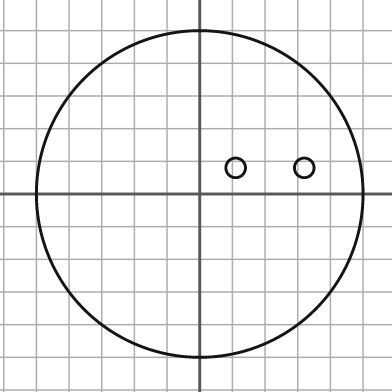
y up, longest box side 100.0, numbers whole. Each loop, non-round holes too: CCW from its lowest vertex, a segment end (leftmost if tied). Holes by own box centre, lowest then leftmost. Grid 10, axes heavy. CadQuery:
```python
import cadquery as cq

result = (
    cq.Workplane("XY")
    .moveTo(0.0, 0.0)
    .circle(50.0)
    .moveTo(11.0, 8.0)
    .circle(3.0)
    .moveTo(32.0, 8.0)
    .circle(3.0)
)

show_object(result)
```